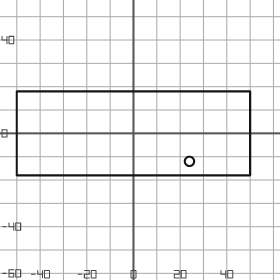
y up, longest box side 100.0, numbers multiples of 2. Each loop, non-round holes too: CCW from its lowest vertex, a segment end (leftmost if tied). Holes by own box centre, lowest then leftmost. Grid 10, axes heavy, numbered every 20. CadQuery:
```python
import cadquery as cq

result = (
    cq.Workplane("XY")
    .moveTo(-50.0, -18.0)
    .lineTo(50.0, -18.0)
    .lineTo(50.0, 18.0)
    .lineTo(-50.0, 18.0)
    .close()
    .moveTo(24.0, -12.0)
    .circle(2.0)
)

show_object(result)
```